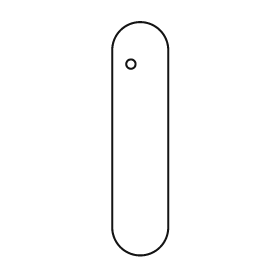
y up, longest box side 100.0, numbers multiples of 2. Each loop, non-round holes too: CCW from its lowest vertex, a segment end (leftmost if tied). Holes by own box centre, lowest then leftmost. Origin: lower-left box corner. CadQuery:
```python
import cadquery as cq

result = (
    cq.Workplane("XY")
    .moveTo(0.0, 12.0)
    .threePointArc((12.0, 0.0), (24.0, 12.0))
    .lineTo(24.0, 88.0)
    .threePointArc((12.0, 100.0), (0.0, 88.0))
    .close()
    .moveTo(8.0, 82.0)
    .circle(2.0)
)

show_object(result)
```